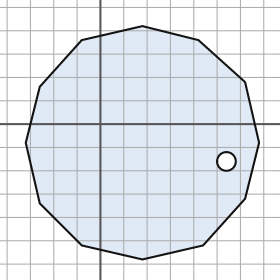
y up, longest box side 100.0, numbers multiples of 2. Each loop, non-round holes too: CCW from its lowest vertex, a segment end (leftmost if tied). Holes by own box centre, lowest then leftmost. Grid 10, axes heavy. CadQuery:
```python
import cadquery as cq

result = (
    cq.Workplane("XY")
    .moveTo(18.0, -58.0)
    .lineTo(44.0, -52.0)
    .lineTo(62.0, -32.0)
    .lineTo(68.0, -8.0)
    .lineTo(62.0, 18.0)
    .lineTo(42.0, 36.0)
    .lineTo(18.0, 42.0)
    .lineTo(-8.0, 36.0)
    .lineTo(-26.0, 16.0)
    .lineTo(-32.0, -8.0)
    .lineTo(-26.0, -34.0)
    .lineTo(-8.0, -52.0)
    .close()
    .moveTo(54.0, -16.0)
    .circle(4.0)
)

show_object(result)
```